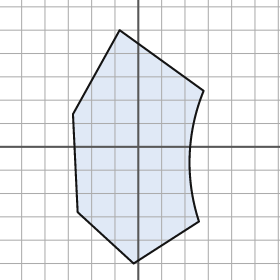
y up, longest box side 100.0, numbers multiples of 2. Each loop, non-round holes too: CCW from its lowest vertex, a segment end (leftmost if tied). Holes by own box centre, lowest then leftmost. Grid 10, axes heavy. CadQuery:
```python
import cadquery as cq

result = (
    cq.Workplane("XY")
    .moveTo(-2.0, -50.0)
    .lineTo(26.0, -32.0)
    .threePointArc((22.0, -4.0), (28.0, 24.0))
    .lineTo(-8.0, 50.0)
    .lineTo(-28.0, 14.0)
    .lineTo(-26.0, -28.0)
    .close()
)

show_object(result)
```